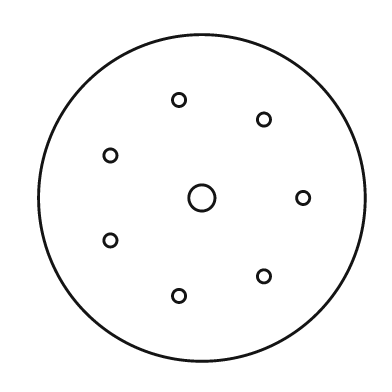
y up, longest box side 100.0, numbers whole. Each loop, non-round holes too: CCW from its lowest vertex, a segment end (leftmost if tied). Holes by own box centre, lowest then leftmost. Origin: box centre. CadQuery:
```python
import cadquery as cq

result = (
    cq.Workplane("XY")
    .moveTo(0.0, 0.0)
    .circle(50.0)
    .moveTo(-7.0, -30.0)
    .circle(2.0)
    .moveTo(19.0, -24.0)
    .circle(2.0)
    .moveTo(-28.0, -13.0)
    .circle(2.0)
    .moveTo(0.0, 0.0)
    .circle(4.0)
    .moveTo(31.0, 0.0)
    .circle(2.0)
    .moveTo(-28.0, 13.0)
    .circle(2.0)
    .moveTo(19.0, 24.0)
    .circle(2.0)
    .moveTo(-7.0, 30.0)
    .circle(2.0)
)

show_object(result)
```